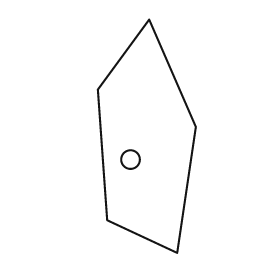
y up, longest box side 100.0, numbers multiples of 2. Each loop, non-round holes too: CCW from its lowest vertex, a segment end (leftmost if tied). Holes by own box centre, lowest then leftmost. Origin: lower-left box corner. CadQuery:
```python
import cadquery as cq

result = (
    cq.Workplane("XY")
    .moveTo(34.0, 0.0)
    .lineTo(42.0, 54.0)
    .lineTo(22.0, 100.0)
    .lineTo(0.0, 70.0)
    .lineTo(4.0, 14.0)
    .close()
    .moveTo(14.0, 40.0)
    .circle(4.0)
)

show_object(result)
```